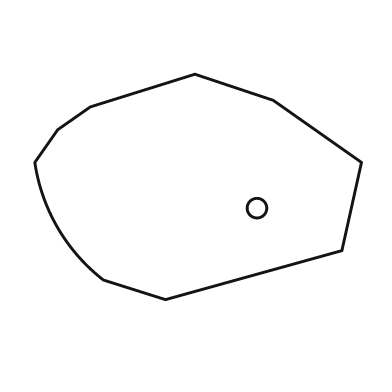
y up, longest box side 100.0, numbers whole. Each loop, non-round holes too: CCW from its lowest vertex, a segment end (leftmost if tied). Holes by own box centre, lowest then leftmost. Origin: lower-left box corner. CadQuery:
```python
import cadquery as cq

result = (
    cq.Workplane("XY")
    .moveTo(40.0, 0.0)
    .lineTo(94.0, 15.0)
    .lineTo(100.0, 42.0)
    .lineTo(73.0, 61.0)
    .lineTo(49.0, 69.0)
    .lineTo(17.0, 59.0)
    .lineTo(7.0, 52.0)
    .lineTo(0.0, 42.0)
    .threePointArc((7.0, 22.0), (21.0, 6.0))
    .close()
    .moveTo(68.0, 28.0)
    .circle(3.0)
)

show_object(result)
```